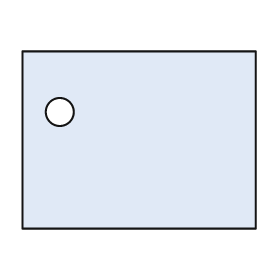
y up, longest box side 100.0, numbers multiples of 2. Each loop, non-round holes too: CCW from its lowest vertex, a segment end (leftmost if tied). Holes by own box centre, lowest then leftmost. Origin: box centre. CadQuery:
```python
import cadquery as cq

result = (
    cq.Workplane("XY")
    .moveTo(-50.0, -38.0)
    .lineTo(50.0, -38.0)
    .lineTo(50.0, 38.0)
    .lineTo(-50.0, 38.0)
    .close()
    .moveTo(-34.0, 12.0)
    .circle(6.0)
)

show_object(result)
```